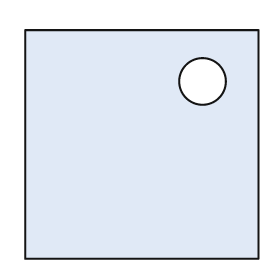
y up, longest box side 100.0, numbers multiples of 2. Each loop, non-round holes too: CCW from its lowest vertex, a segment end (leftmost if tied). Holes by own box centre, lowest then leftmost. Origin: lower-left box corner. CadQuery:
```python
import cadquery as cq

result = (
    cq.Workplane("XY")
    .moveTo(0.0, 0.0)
    .lineTo(100.0, 0.0)
    .lineTo(100.0, 98.0)
    .lineTo(0.0, 98.0)
    .close()
    .moveTo(76.0, 76.0)
    .circle(10.0)
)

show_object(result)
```